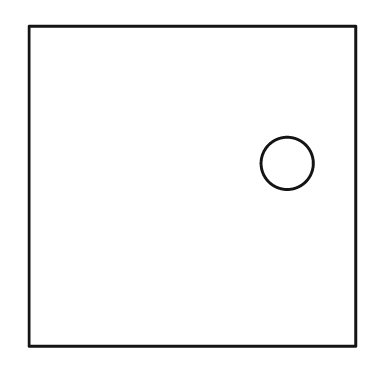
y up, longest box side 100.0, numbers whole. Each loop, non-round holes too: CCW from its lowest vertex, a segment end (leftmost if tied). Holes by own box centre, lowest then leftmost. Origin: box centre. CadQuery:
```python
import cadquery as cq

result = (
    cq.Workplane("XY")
    .moveTo(-50.0, -49.0)
    .lineTo(50.0, -49.0)
    .lineTo(50.0, 49.0)
    .lineTo(-50.0, 49.0)
    .close()
    .moveTo(29.0, 7.0)
    .circle(8.0)
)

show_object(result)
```